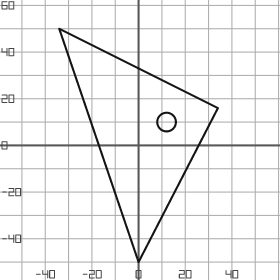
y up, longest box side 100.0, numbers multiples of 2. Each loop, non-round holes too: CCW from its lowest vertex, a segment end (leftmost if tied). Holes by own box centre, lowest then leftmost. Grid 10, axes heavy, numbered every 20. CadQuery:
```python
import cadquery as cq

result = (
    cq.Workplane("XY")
    .moveTo(0.0, -50.0)
    .lineTo(34.0, 16.0)
    .lineTo(-34.0, 50.0)
    .close()
    .moveTo(12.0, 10.0)
    .circle(4.0)
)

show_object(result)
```